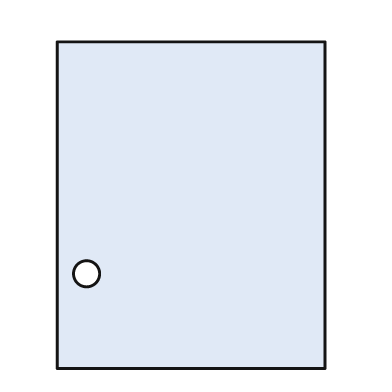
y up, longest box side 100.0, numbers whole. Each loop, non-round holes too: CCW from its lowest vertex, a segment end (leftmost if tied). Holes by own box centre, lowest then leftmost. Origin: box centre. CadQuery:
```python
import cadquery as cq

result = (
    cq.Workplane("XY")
    .moveTo(-41.0, -50.0)
    .lineTo(41.0, -50.0)
    .lineTo(41.0, 50.0)
    .lineTo(-41.0, 50.0)
    .close()
    .moveTo(-32.0, -21.0)
    .circle(4.0)
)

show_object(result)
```